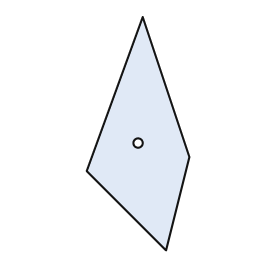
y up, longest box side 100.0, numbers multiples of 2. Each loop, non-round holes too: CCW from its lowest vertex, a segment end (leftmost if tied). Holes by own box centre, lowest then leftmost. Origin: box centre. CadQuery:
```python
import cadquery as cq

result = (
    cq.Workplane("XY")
    .moveTo(12.0, -50.0)
    .lineTo(22.0, -10.0)
    .lineTo(2.0, 50.0)
    .lineTo(-22.0, -16.0)
    .close()
    .moveTo(0.0, -4.0)
    .circle(2.0)
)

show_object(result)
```